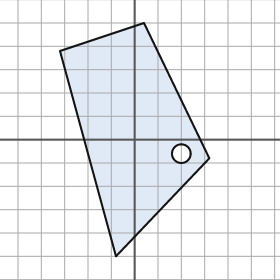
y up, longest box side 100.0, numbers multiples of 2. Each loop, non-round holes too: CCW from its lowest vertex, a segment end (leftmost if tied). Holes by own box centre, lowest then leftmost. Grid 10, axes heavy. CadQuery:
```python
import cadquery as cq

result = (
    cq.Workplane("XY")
    .moveTo(-8.0, -50.0)
    .lineTo(32.0, -8.0)
    .lineTo(4.0, 50.0)
    .lineTo(-32.0, 38.0)
    .close()
    .moveTo(20.0, -6.0)
    .circle(4.0)
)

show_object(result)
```